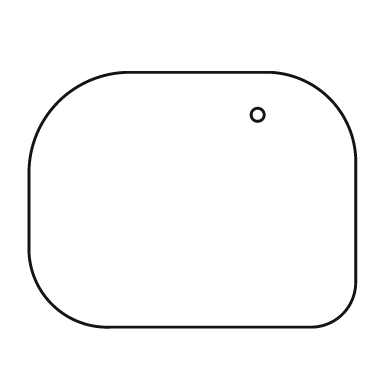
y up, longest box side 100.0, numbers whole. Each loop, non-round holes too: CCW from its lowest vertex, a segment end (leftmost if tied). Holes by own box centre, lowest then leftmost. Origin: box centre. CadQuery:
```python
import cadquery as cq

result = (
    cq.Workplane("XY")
    .moveTo(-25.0, -39.0)
    .lineTo(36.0, -39.0)
    .threePointArc((46.0, -35.0), (50.0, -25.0))
    .lineTo(50.0, 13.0)
    .threePointArc((42.0, 31.0), (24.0, 39.0))
    .lineTo(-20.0, 39.0)
    .threePointArc((-41.0, 30.0), (-50.0, 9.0))
    .lineTo(-50.0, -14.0)
    .threePointArc((-43.0, -32.0), (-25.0, -39.0))
    .close()
    .moveTo(20.0, 26.0)
    .circle(2.0)
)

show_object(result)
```